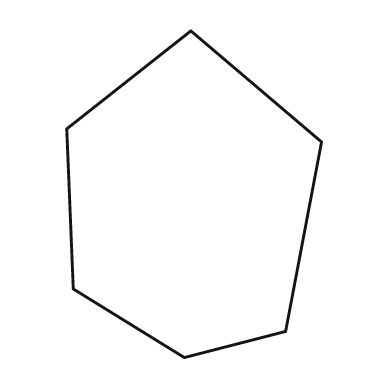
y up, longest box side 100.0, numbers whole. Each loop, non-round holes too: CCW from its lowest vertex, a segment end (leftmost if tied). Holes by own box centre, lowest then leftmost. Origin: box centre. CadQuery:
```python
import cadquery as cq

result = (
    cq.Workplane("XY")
    .moveTo(-3.0, -50.0)
    .lineTo(28.0, -42.0)
    .lineTo(39.0, 16.0)
    .lineTo(-1.0, 50.0)
    .lineTo(-39.0, 20.0)
    .lineTo(-37.0, -29.0)
    .close()
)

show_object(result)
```